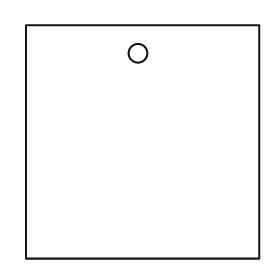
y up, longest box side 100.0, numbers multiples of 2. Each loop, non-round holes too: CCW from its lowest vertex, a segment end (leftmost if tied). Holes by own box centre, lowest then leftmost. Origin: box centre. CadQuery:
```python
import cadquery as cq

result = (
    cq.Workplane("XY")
    .moveTo(-50.0, -50.0)
    .lineTo(50.0, -50.0)
    .lineTo(50.0, 50.0)
    .lineTo(-50.0, 50.0)
    .close()
    .moveTo(-2.0, 38.0)
    .circle(4.0)
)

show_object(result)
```